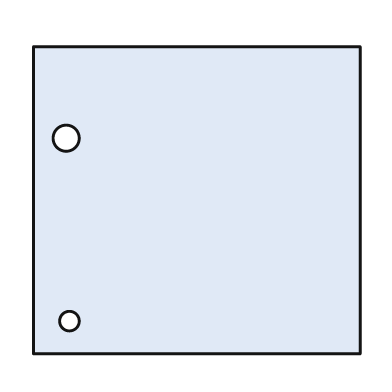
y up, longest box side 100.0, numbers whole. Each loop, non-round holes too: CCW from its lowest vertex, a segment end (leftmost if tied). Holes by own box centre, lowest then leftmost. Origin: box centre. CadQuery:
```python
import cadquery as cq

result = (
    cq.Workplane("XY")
    .moveTo(-50.0, -47.0)
    .lineTo(50.0, -47.0)
    .lineTo(50.0, 47.0)
    .lineTo(-50.0, 47.0)
    .close()
    .moveTo(-39.0, -37.0)
    .circle(3.0)
    .moveTo(-40.0, 19.0)
    .circle(4.0)
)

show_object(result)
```